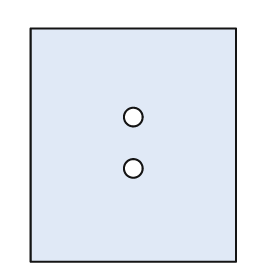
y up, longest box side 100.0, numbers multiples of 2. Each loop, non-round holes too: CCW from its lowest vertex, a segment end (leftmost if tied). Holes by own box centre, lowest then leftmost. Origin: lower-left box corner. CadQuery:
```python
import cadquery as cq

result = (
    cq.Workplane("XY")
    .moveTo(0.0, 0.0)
    .lineTo(88.0, 0.0)
    .lineTo(88.0, 100.0)
    .lineTo(0.0, 100.0)
    .close()
    .moveTo(44.0, 40.0)
    .circle(4.0)
    .moveTo(44.0, 62.0)
    .circle(4.0)
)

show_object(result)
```